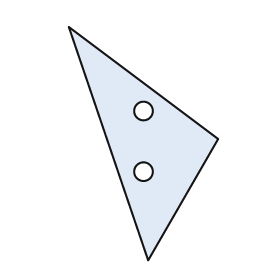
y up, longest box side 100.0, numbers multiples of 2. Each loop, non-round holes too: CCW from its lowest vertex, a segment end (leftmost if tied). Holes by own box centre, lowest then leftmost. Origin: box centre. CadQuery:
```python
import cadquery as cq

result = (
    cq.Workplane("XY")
    .moveTo(2.0, -50.0)
    .lineTo(32.0, 2.0)
    .lineTo(-32.0, 50.0)
    .close()
    .moveTo(0.0, -12.0)
    .circle(4.0)
    .moveTo(0.0, 14.0)
    .circle(4.0)
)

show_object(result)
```